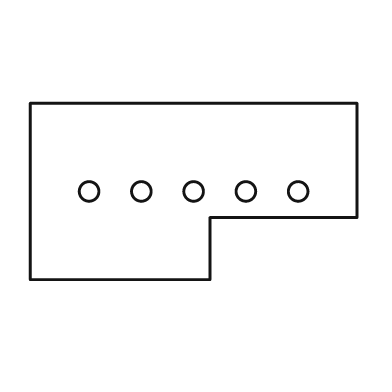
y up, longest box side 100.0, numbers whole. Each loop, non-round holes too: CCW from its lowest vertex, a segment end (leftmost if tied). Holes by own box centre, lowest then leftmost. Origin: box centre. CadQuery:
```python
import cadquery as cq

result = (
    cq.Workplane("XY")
    .moveTo(-50.0, -27.0)
    .lineTo(5.0, -27.0)
    .lineTo(5.0, -8.0)
    .lineTo(50.0, -8.0)
    .lineTo(50.0, 27.0)
    .lineTo(-50.0, 27.0)
    .close()
    .moveTo(-32.0, 0.0)
    .circle(3.0)
    .moveTo(-16.0, 0.0)
    .circle(3.0)
    .moveTo(0.0, 0.0)
    .circle(3.0)
    .moveTo(16.0, 0.0)
    .circle(3.0)
    .moveTo(32.0, 0.0)
    .circle(3.0)
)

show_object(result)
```